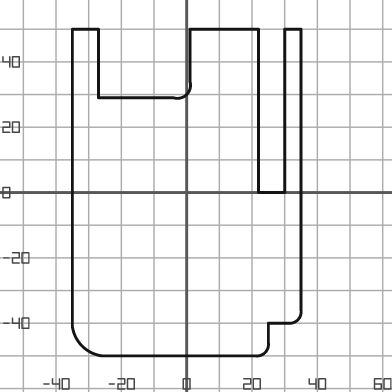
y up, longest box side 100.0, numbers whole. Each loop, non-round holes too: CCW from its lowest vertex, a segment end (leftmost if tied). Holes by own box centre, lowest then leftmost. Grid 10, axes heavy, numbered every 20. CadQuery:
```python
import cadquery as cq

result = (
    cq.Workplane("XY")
    .moveTo(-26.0, -50.0)
    .lineTo(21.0, -50.0)
    .threePointArc((24.0, -49.0), (25.0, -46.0))
    .lineTo(25.0, -40.0)
    .lineTo(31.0, -40.0)
    .threePointArc((34.0, -39.0), (35.0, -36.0))
    .lineTo(35.0, 50.0)
    .lineTo(30.0, 50.0)
    .lineTo(30.0, 0.0)
    .lineTo(22.0, 0.0)
    .lineTo(22.0, 50.0)
    .lineTo(1.0, 50.0)
    .lineTo(1.0, 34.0)
    .threePointArc((0.0, 30.0), (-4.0, 29.0))
    .lineTo(-27.0, 29.0)
    .lineTo(-27.0, 50.0)
    .lineTo(-35.0, 50.0)
    .lineTo(-35.0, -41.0)
    .threePointArc((-32.0, -47.0), (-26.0, -50.0))
    .close()
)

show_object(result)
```